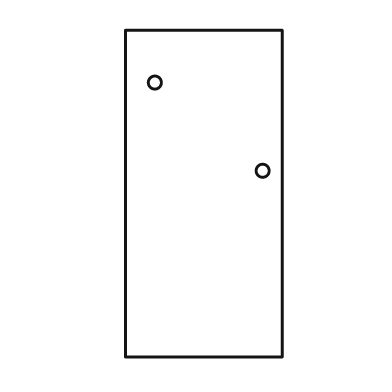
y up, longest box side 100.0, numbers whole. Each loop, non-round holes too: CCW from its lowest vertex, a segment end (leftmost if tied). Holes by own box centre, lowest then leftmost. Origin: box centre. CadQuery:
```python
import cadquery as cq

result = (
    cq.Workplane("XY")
    .moveTo(-24.0, -50.0)
    .lineTo(24.0, -50.0)
    .lineTo(24.0, 50.0)
    .lineTo(-24.0, 50.0)
    .close()
    .moveTo(18.0, 7.0)
    .circle(2.0)
    .moveTo(-15.0, 34.0)
    .circle(2.0)
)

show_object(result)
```